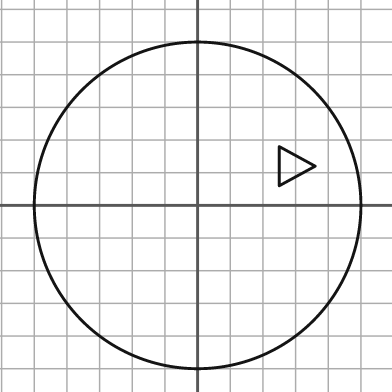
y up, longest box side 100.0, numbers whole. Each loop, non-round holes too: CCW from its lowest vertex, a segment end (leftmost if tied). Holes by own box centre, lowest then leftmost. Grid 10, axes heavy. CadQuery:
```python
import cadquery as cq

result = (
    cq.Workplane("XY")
    .moveTo(0.0, 0.0)
    .circle(50.0)
    .moveTo(25.0, 6.0)
    .lineTo(36.0, 12.0)
    .lineTo(25.0, 18.0)
    .close()
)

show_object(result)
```